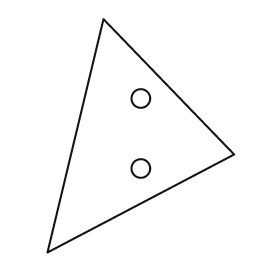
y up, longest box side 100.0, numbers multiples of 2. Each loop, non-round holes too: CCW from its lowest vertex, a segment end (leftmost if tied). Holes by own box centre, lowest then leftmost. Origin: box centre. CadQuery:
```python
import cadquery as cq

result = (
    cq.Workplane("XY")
    .moveTo(-40.0, -50.0)
    .lineTo(40.0, -8.0)
    .lineTo(-16.0, 50.0)
    .close()
    .moveTo(0.0, -14.0)
    .circle(4.0)
    .moveTo(0.0, 16.0)
    .circle(4.0)
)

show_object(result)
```